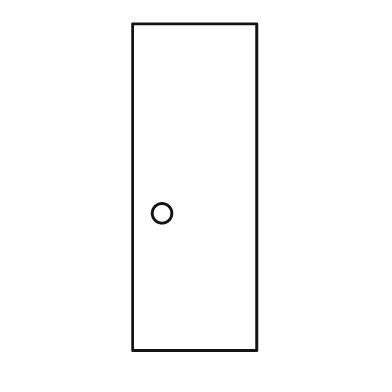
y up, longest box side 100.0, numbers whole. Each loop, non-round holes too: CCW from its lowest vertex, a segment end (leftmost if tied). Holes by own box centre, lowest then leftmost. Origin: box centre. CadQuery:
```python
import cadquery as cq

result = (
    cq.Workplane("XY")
    .moveTo(-19.0, -50.0)
    .lineTo(19.0, -50.0)
    .lineTo(19.0, 50.0)
    .lineTo(-19.0, 50.0)
    .close()
    .moveTo(-10.0, -8.0)
    .circle(3.0)
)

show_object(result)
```